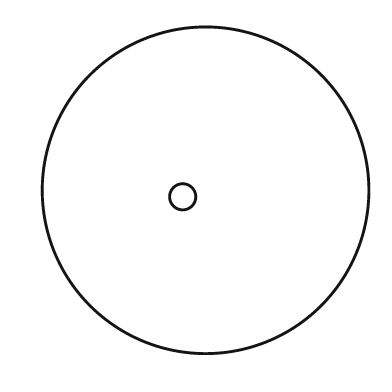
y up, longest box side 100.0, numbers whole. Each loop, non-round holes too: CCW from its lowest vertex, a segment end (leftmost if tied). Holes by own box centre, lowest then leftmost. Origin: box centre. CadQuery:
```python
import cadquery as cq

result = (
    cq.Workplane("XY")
    .moveTo(0.0, 0.0)
    .circle(50.0)
    .moveTo(-7.0, -2.0)
    .circle(4.0)
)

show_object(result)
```